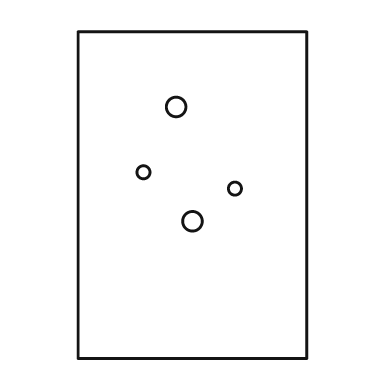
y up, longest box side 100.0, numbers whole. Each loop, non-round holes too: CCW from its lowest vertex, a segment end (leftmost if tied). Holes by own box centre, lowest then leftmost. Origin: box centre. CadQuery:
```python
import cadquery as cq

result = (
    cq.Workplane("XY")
    .moveTo(-35.0, -50.0)
    .lineTo(35.0, -50.0)
    .lineTo(35.0, 50.0)
    .lineTo(-35.0, 50.0)
    .close()
    .moveTo(0.0, -8.0)
    .circle(3.0)
    .moveTo(13.0, 2.0)
    .circle(2.0)
    .moveTo(-15.0, 7.0)
    .circle(2.0)
    .moveTo(-5.0, 27.0)
    .circle(3.0)
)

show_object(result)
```